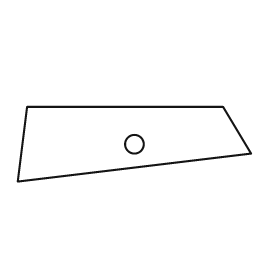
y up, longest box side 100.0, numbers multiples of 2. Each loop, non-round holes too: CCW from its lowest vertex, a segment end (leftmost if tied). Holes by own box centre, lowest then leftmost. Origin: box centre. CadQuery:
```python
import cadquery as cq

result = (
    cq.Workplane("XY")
    .moveTo(-50.0, -16.0)
    .lineTo(50.0, -4.0)
    .lineTo(38.0, 16.0)
    .lineTo(-46.0, 16.0)
    .close()
    .moveTo(0.0, 0.0)
    .circle(4.0)
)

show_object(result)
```